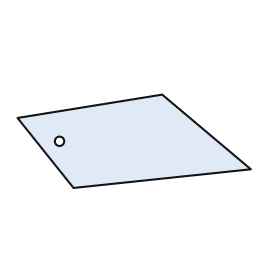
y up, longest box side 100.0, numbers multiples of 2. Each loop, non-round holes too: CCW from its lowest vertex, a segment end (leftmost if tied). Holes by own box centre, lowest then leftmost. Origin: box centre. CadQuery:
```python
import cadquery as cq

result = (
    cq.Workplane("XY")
    .moveTo(-26.0, -20.0)
    .lineTo(50.0, -12.0)
    .lineTo(12.0, 20.0)
    .lineTo(-50.0, 10.0)
    .close()
    .moveTo(-32.0, 0.0)
    .circle(2.0)
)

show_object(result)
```